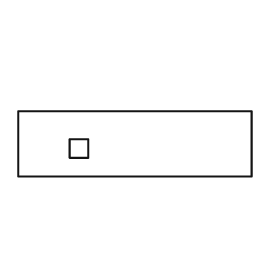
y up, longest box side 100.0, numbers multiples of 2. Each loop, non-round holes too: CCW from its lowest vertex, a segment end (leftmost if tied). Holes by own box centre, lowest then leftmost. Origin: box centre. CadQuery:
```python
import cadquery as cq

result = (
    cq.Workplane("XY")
    .moveTo(-50.0, -14.0)
    .lineTo(50.0, -14.0)
    .lineTo(50.0, 14.0)
    .lineTo(-50.0, 14.0)
    .close()
    .moveTo(-28.0, -6.0)
    .lineTo(-20.0, -6.0)
    .lineTo(-20.0, 2.0)
    .lineTo(-28.0, 2.0)
    .close()
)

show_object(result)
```